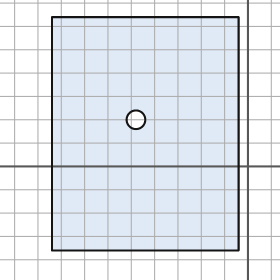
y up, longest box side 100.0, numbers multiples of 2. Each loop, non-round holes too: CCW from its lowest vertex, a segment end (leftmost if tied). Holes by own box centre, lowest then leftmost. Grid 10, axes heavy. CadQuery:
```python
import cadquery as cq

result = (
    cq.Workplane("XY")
    .moveTo(-84.0, -36.0)
    .lineTo(-4.0, -36.0)
    .lineTo(-4.0, 64.0)
    .lineTo(-84.0, 64.0)
    .close()
    .moveTo(-48.0, 20.0)
    .circle(4.0)
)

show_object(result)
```